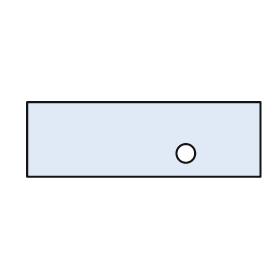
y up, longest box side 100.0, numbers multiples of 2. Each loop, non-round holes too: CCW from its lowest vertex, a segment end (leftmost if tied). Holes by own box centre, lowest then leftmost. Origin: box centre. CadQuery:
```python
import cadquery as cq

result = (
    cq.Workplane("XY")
    .moveTo(-50.0, -16.0)
    .lineTo(50.0, -16.0)
    .lineTo(50.0, 16.0)
    .lineTo(-50.0, 16.0)
    .close()
    .moveTo(18.0, -6.0)
    .circle(4.0)
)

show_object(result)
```